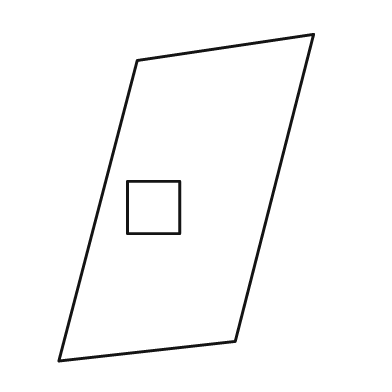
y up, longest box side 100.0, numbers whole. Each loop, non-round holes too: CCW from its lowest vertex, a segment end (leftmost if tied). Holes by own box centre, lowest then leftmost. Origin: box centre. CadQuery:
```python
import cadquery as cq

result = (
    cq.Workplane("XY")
    .moveTo(-39.0, -50.0)
    .lineTo(15.0, -44.0)
    .lineTo(39.0, 50.0)
    .lineTo(-15.0, 42.0)
    .close()
    .moveTo(-18.0, -11.0)
    .lineTo(-2.0, -11.0)
    .lineTo(-2.0, 5.0)
    .lineTo(-18.0, 5.0)
    .close()
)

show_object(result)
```